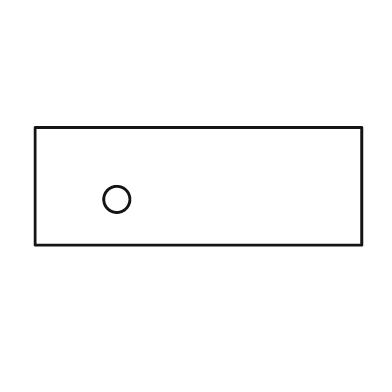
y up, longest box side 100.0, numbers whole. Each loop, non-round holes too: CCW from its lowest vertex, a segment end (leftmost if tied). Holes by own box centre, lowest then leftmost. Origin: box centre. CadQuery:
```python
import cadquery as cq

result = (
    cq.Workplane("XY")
    .moveTo(-50.0, -18.0)
    .lineTo(50.0, -18.0)
    .lineTo(50.0, 18.0)
    .lineTo(-50.0, 18.0)
    .close()
    .moveTo(-25.0, -4.0)
    .circle(4.0)
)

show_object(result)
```